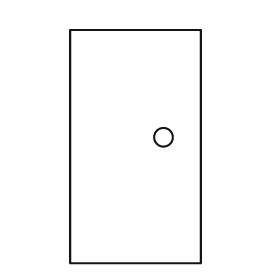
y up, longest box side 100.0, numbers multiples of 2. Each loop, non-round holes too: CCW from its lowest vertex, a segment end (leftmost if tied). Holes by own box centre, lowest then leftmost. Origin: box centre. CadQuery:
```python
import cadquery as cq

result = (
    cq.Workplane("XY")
    .moveTo(-28.0, -50.0)
    .lineTo(28.0, -50.0)
    .lineTo(28.0, 50.0)
    .lineTo(-28.0, 50.0)
    .close()
    .moveTo(12.0, 4.0)
    .circle(4.0)
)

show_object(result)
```